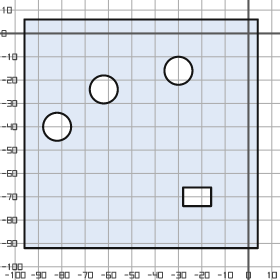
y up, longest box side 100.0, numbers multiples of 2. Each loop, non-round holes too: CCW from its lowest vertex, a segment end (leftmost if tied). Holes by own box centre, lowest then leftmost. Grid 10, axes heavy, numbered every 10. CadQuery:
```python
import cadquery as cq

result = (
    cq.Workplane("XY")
    .moveTo(-96.0, -92.0)
    .lineTo(4.0, -92.0)
    .lineTo(4.0, 6.0)
    .lineTo(-96.0, 6.0)
    .close()
    .moveTo(-28.0, -74.0)
    .lineTo(-16.0, -74.0)
    .lineTo(-16.0, -66.0)
    .lineTo(-28.0, -66.0)
    .close()
    .moveTo(-82.0, -40.0)
    .circle(6.0)
    .moveTo(-62.0, -24.0)
    .circle(6.0)
    .moveTo(-30.0, -16.0)
    .circle(6.0)
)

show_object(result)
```